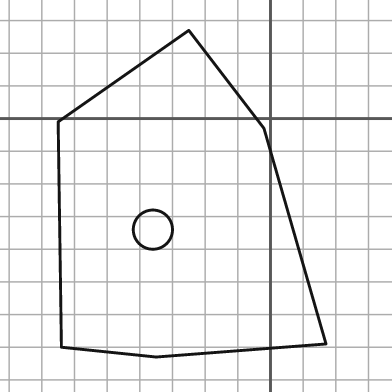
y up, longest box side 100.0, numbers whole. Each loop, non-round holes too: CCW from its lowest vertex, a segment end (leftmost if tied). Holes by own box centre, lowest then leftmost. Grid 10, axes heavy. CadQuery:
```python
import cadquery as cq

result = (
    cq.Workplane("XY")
    .moveTo(-35.0, -73.0)
    .lineTo(17.0, -69.0)
    .lineTo(-2.0, -3.0)
    .lineTo(-25.0, 27.0)
    .lineTo(-65.0, -1.0)
    .lineTo(-64.0, -70.0)
    .close()
    .moveTo(-36.0, -34.0)
    .circle(6.0)
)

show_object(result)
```